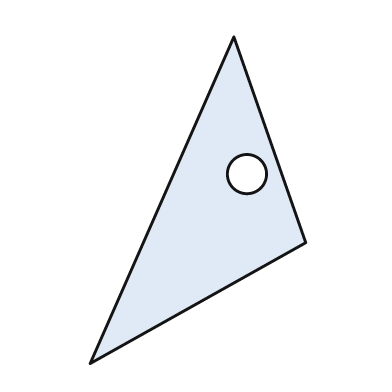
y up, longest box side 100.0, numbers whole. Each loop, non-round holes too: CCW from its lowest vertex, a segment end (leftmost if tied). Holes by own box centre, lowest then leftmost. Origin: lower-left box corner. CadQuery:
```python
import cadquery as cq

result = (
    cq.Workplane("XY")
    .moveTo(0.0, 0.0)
    .lineTo(66.0, 37.0)
    .lineTo(44.0, 100.0)
    .close()
    .moveTo(48.0, 58.0)
    .circle(6.0)
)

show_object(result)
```